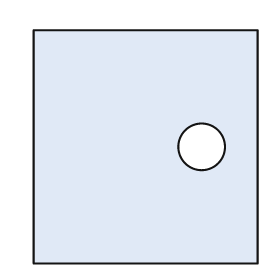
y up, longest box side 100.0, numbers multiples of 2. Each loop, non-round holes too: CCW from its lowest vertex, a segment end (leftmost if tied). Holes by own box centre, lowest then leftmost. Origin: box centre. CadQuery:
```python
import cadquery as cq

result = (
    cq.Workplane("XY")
    .moveTo(-48.0, -50.0)
    .lineTo(48.0, -50.0)
    .lineTo(48.0, 50.0)
    .lineTo(-48.0, 50.0)
    .close()
    .moveTo(24.0, 0.0)
    .circle(10.0)
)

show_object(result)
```